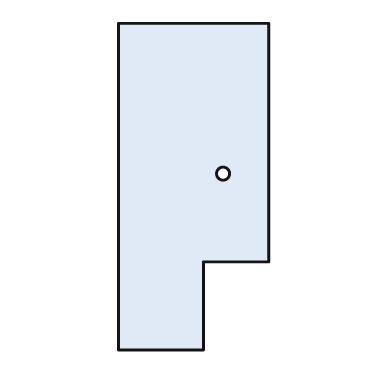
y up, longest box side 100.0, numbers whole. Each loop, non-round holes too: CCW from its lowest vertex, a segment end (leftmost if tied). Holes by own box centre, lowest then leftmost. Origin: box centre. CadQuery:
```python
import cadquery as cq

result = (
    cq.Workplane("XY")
    .moveTo(-23.0, -50.0)
    .lineTo(3.0, -50.0)
    .lineTo(3.0, -23.0)
    .lineTo(23.0, -23.0)
    .lineTo(23.0, 50.0)
    .lineTo(-23.0, 50.0)
    .close()
    .moveTo(9.0, 4.0)
    .circle(2.0)
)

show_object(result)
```